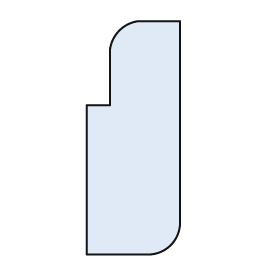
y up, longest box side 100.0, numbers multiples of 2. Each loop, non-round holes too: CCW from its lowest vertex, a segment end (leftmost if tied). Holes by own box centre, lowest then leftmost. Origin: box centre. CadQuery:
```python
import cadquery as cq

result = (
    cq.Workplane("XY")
    .moveTo(-20.0, -50.0)
    .lineTo(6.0, -50.0)
    .threePointArc((16.0, -46.0), (20.0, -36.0))
    .lineTo(20.0, 50.0)
    .lineTo(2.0, 50.0)
    .threePointArc((-6.0, 46.0), (-10.0, 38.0))
    .lineTo(-10.0, 14.0)
    .lineTo(-20.0, 14.0)
    .close()
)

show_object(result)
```